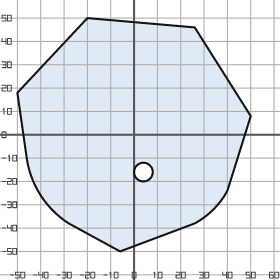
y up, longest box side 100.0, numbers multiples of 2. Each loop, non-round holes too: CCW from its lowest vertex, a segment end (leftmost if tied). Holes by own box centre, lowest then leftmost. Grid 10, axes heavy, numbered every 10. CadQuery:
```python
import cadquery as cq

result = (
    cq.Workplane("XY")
    .moveTo(-6.0, -50.0)
    .lineTo(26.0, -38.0)
    .threePointArc((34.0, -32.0), (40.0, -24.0))
    .lineTo(50.0, 8.0)
    .lineTo(26.0, 46.0)
    .lineTo(-20.0, 50.0)
    .lineTo(-50.0, 18.0)
    .lineTo(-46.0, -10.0)
    .threePointArc((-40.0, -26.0), (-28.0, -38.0))
    .close()
    .moveTo(4.0, -16.0)
    .circle(4.0)
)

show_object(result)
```